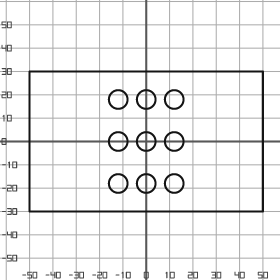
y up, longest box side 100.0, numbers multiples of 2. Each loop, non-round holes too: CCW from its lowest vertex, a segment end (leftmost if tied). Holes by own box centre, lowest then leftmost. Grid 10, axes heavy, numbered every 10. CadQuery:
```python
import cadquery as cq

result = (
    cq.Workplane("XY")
    .moveTo(-50.0, -30.0)
    .lineTo(50.0, -30.0)
    .lineTo(50.0, 30.0)
    .lineTo(-50.0, 30.0)
    .close()
    .moveTo(-12.0, -18.0)
    .circle(4.0)
    .moveTo(0.0, -18.0)
    .circle(4.0)
    .moveTo(12.0, -18.0)
    .circle(4.0)
    .moveTo(-12.0, 0.0)
    .circle(4.0)
    .moveTo(0.0, 0.0)
    .circle(4.0)
    .moveTo(12.0, 0.0)
    .circle(4.0)
    .moveTo(-12.0, 18.0)
    .circle(4.0)
    .moveTo(0.0, 18.0)
    .circle(4.0)
    .moveTo(12.0, 18.0)
    .circle(4.0)
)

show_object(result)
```